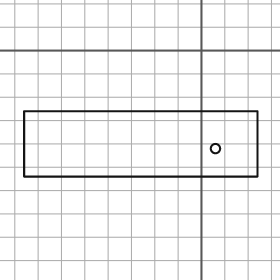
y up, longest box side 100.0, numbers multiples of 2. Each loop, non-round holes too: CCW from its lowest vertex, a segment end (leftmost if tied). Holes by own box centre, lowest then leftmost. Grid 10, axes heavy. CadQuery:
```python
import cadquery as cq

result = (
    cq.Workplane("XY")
    .moveTo(-76.0, -54.0)
    .lineTo(24.0, -54.0)
    .lineTo(24.0, -26.0)
    .lineTo(-76.0, -26.0)
    .close()
    .moveTo(6.0, -42.0)
    .circle(2.0)
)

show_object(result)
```